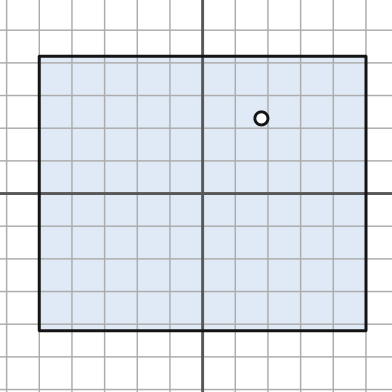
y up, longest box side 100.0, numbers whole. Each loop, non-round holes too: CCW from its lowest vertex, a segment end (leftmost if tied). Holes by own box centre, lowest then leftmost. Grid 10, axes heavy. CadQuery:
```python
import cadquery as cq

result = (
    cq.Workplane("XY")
    .moveTo(-50.0, -42.0)
    .lineTo(50.0, -42.0)
    .lineTo(50.0, 42.0)
    .lineTo(-50.0, 42.0)
    .close()
    .moveTo(18.0, 23.0)
    .circle(2.0)
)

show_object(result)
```